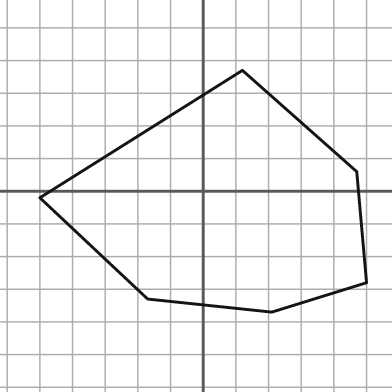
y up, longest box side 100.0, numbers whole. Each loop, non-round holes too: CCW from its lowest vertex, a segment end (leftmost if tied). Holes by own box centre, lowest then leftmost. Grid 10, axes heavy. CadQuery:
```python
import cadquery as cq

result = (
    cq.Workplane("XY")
    .moveTo(21.0, -37.0)
    .lineTo(50.0, -28.0)
    .lineTo(47.0, 6.0)
    .lineTo(12.0, 37.0)
    .lineTo(-50.0, -2.0)
    .lineTo(-17.0, -33.0)
    .close()
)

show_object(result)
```